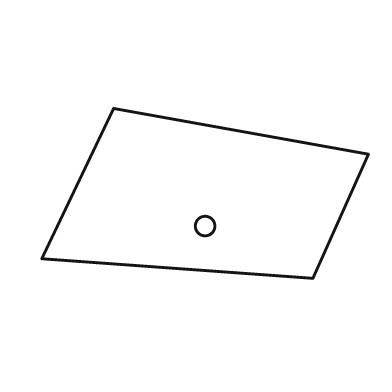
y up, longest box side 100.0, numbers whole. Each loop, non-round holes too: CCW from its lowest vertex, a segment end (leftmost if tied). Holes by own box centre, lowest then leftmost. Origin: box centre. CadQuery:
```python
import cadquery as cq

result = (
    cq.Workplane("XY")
    .moveTo(33.0, -26.0)
    .lineTo(50.0, 12.0)
    .lineTo(-28.0, 26.0)
    .lineTo(-50.0, -20.0)
    .close()
    .moveTo(0.0, -10.0)
    .circle(3.0)
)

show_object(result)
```